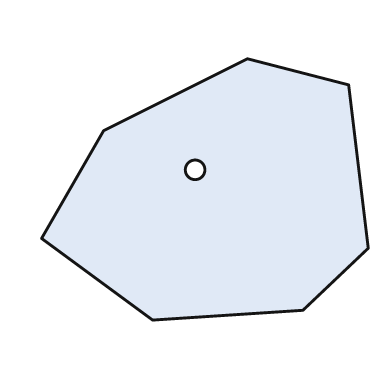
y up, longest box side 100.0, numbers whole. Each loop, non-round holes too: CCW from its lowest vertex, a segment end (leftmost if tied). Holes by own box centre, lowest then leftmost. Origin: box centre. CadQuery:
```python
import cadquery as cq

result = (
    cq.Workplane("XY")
    .moveTo(-16.0, -40.0)
    .lineTo(30.0, -37.0)
    .lineTo(50.0, -18.0)
    .lineTo(44.0, 32.0)
    .lineTo(13.0, 40.0)
    .lineTo(-31.0, 18.0)
    .lineTo(-50.0, -15.0)
    .close()
    .moveTo(-3.0, 6.0)
    .circle(3.0)
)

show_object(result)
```